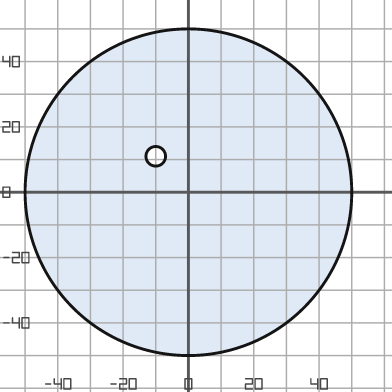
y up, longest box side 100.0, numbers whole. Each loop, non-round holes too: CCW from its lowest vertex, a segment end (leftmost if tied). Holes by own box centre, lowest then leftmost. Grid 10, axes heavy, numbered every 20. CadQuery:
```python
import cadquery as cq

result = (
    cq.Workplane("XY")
    .moveTo(0.0, 0.0)
    .circle(50.0)
    .moveTo(-10.0, 11.0)
    .circle(3.0)
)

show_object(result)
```